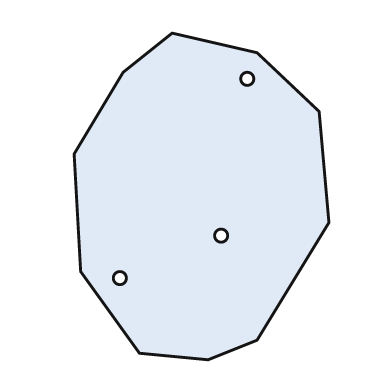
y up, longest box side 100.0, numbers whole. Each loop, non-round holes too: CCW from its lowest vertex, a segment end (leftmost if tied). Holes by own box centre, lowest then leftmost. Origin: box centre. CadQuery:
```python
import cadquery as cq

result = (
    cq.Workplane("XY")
    .moveTo(2.0, -50.0)
    .lineTo(17.0, -44.0)
    .lineTo(39.0, -8.0)
    .lineTo(36.0, 26.0)
    .lineTo(17.0, 44.0)
    .lineTo(-9.0, 50.0)
    .lineTo(-24.0, 38.0)
    .lineTo(-39.0, 13.0)
    .lineTo(-37.0, -23.0)
    .lineTo(-19.0, -48.0)
    .close()
    .moveTo(-25.0, -25.0)
    .circle(2.0)
    .moveTo(6.0, -12.0)
    .circle(2.0)
    .moveTo(14.0, 36.0)
    .circle(2.0)
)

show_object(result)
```